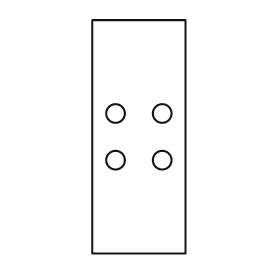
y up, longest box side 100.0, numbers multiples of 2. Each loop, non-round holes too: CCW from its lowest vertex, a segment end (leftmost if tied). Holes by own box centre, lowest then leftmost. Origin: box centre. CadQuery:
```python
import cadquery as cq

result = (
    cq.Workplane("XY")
    .moveTo(-20.0, -50.0)
    .lineTo(20.0, -50.0)
    .lineTo(20.0, 50.0)
    .lineTo(-20.0, 50.0)
    .close()
    .moveTo(-10.0, -10.0)
    .circle(4.0)
    .moveTo(10.0, -10.0)
    .circle(4.0)
    .moveTo(-10.0, 10.0)
    .circle(4.0)
    .moveTo(10.0, 10.0)
    .circle(4.0)
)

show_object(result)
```